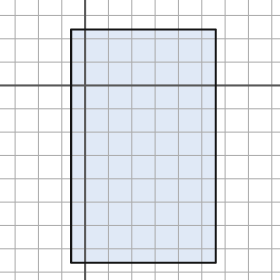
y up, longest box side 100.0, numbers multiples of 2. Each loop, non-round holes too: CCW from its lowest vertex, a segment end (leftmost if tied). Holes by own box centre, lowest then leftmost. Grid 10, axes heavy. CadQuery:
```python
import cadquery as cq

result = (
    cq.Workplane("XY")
    .moveTo(-6.0, -76.0)
    .lineTo(56.0, -76.0)
    .lineTo(56.0, 24.0)
    .lineTo(-6.0, 24.0)
    .close()
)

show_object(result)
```